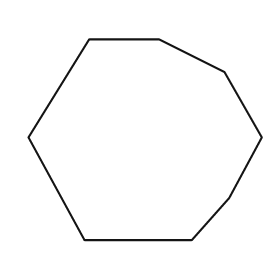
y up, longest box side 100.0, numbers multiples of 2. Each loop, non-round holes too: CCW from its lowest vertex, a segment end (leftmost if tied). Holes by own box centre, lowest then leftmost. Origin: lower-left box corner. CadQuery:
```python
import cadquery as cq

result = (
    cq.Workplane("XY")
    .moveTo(24.0, 0.0)
    .lineTo(70.0, 0.0)
    .lineTo(86.0, 18.0)
    .lineTo(100.0, 44.0)
    .lineTo(84.0, 72.0)
    .lineTo(56.0, 86.0)
    .lineTo(26.0, 86.0)
    .lineTo(0.0, 44.0)
    .close()
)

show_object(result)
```